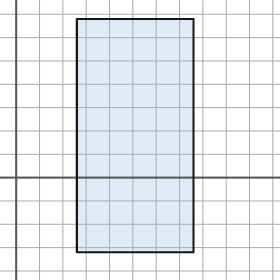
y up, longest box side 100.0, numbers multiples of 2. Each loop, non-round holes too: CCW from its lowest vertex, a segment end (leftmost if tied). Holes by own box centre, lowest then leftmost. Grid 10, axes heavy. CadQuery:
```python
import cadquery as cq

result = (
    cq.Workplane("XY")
    .moveTo(26.0, -32.0)
    .lineTo(76.0, -32.0)
    .lineTo(76.0, 68.0)
    .lineTo(26.0, 68.0)
    .close()
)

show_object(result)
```